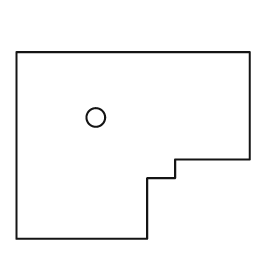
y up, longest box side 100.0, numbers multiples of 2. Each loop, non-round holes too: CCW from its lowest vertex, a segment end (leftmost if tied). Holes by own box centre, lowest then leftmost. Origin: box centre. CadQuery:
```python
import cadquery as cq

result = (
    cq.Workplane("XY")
    .moveTo(-50.0, -40.0)
    .lineTo(6.0, -40.0)
    .lineTo(6.0, -14.0)
    .lineTo(18.0, -14.0)
    .lineTo(18.0, -6.0)
    .lineTo(50.0, -6.0)
    .lineTo(50.0, 40.0)
    .lineTo(-50.0, 40.0)
    .close()
    .moveTo(-16.0, 12.0)
    .circle(4.0)
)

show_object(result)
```